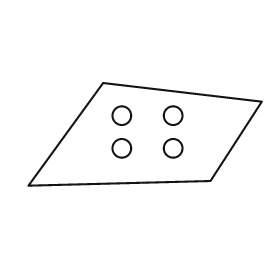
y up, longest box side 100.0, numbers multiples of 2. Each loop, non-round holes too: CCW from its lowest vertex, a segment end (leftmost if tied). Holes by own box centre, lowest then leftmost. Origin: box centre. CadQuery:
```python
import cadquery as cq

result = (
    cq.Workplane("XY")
    .moveTo(-50.0, -22.0)
    .lineTo(28.0, -20.0)
    .lineTo(50.0, 14.0)
    .lineTo(-18.0, 22.0)
    .close()
    .moveTo(-10.0, -6.0)
    .circle(4.0)
    .moveTo(12.0, -6.0)
    .circle(4.0)
    .moveTo(-10.0, 8.0)
    .circle(4.0)
    .moveTo(12.0, 8.0)
    .circle(4.0)
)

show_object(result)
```